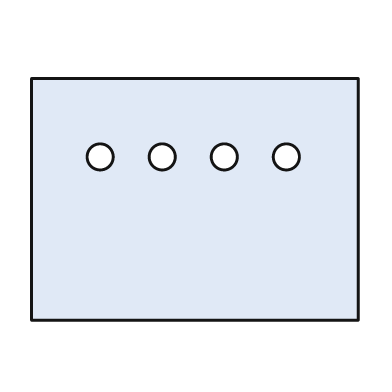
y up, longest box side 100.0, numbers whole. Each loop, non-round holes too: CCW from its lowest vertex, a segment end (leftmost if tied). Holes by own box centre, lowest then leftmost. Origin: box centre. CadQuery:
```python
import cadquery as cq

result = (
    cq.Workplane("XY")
    .moveTo(-50.0, -37.0)
    .lineTo(50.0, -37.0)
    .lineTo(50.0, 37.0)
    .lineTo(-50.0, 37.0)
    .close()
    .moveTo(-29.0, 13.0)
    .circle(4.0)
    .moveTo(-10.0, 13.0)
    .circle(4.0)
    .moveTo(9.0, 13.0)
    .circle(4.0)
    .moveTo(28.0, 13.0)
    .circle(4.0)
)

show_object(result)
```